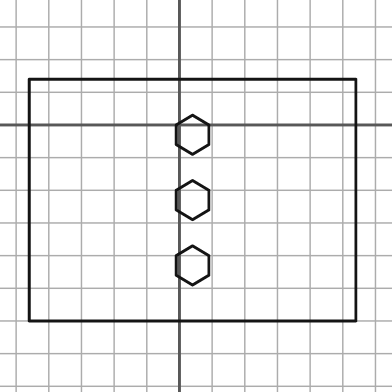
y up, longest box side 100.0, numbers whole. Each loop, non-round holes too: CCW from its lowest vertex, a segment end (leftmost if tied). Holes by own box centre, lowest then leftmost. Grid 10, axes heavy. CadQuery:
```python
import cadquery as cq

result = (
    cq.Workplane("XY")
    .moveTo(-46.0, -60.0)
    .lineTo(54.0, -60.0)
    .lineTo(54.0, 14.0)
    .lineTo(-46.0, 14.0)
    .close()
    .moveTo(4.0, -49.0)
    .lineTo(9.0, -46.0)
    .lineTo(9.0, -40.0)
    .lineTo(4.0, -37.0)
    .lineTo(-1.0, -40.0)
    .lineTo(-1.0, -46.0)
    .close()
    .moveTo(4.0, -29.0)
    .lineTo(9.0, -26.0)
    .lineTo(9.0, -20.0)
    .lineTo(4.0, -17.0)
    .lineTo(-1.0, -20.0)
    .lineTo(-1.0, -26.0)
    .close()
    .moveTo(4.0, -9.0)
    .lineTo(9.0, -6.0)
    .lineTo(9.0, 0.0)
    .lineTo(4.0, 3.0)
    .lineTo(-1.0, 0.0)
    .lineTo(-1.0, -6.0)
    .close()
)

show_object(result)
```